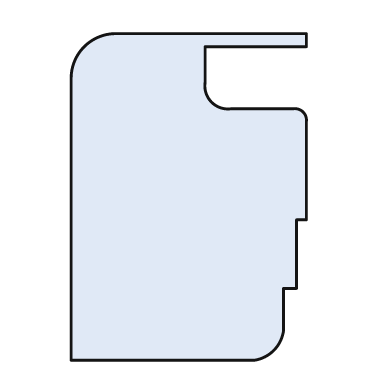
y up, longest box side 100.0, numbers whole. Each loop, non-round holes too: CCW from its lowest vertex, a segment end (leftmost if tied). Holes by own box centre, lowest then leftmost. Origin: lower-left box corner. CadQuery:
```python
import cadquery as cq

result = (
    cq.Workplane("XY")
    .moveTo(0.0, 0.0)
    .lineTo(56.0, 0.0)
    .threePointArc((62.0, 3.0), (65.0, 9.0))
    .lineTo(65.0, 22.0)
    .lineTo(69.0, 22.0)
    .lineTo(69.0, 43.0)
    .lineTo(72.0, 43.0)
    .lineTo(72.0, 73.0)
    .threePointArc((71.0, 76.0), (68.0, 77.0))
    .lineTo(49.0, 77.0)
    .threePointArc((43.0, 79.0), (41.0, 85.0))
    .lineTo(41.0, 96.0)
    .lineTo(72.0, 96.0)
    .lineTo(72.0, 100.0)
    .lineTo(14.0, 100.0)
    .threePointArc((4.0, 96.0), (0.0, 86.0))
    .close()
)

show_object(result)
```